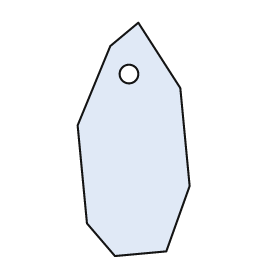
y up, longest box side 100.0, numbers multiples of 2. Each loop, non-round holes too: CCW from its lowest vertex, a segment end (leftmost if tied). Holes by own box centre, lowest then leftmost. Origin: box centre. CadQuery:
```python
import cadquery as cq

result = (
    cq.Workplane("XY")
    .moveTo(-8.0, -50.0)
    .lineTo(14.0, -48.0)
    .lineTo(24.0, -20.0)
    .lineTo(20.0, 22.0)
    .lineTo(2.0, 50.0)
    .lineTo(-10.0, 40.0)
    .lineTo(-24.0, 6.0)
    .lineTo(-20.0, -36.0)
    .close()
    .moveTo(-2.0, 28.0)
    .circle(4.0)
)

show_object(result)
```